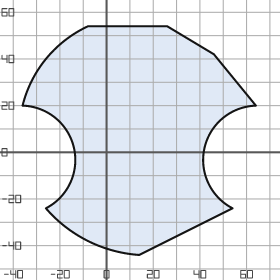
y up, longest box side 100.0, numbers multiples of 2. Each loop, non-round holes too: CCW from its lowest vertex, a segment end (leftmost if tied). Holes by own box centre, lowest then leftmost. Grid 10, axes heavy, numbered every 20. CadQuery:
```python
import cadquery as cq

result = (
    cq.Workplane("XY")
    .moveTo(14.0, -44.0)
    .lineTo(54.0, -24.0)
    .threePointArc((42.0, 2.0), (64.0, 20.0))
    .lineTo(46.0, 42.0)
    .lineTo(26.0, 54.0)
    .lineTo(-8.0, 54.0)
    .threePointArc((-26.0, 40.0), (-36.0, 20.0))
    .threePointArc((-14.0, 2.0), (-26.0, -24.0))
    .threePointArc((-8.0, -38.0), (14.0, -44.0))
    .close()
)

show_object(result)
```